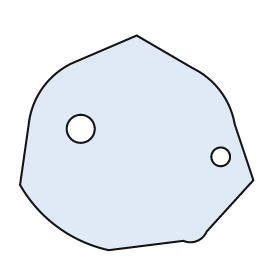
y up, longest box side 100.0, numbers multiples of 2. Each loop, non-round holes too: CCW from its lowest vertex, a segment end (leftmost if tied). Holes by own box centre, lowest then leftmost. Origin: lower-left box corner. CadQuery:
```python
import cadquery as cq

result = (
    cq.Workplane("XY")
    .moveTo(38.0, 0.0)
    .lineTo(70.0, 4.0)
    .threePointArc((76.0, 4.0), (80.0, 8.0))
    .lineTo(100.0, 30.0)
    .lineTo(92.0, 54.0)
    .threePointArc((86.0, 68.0), (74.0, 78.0))
    .lineTo(50.0, 92.0)
    .lineTo(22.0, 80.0)
    .threePointArc((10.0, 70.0), (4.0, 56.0))
    .lineTo(0.0, 28.0)
    .threePointArc((16.0, 10.0), (38.0, 0.0))
    .close()
    .moveTo(86.0, 40.0)
    .circle(4.0)
    .moveTo(26.0, 52.0)
    .circle(6.0)
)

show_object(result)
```